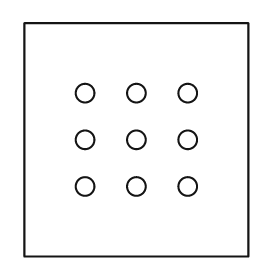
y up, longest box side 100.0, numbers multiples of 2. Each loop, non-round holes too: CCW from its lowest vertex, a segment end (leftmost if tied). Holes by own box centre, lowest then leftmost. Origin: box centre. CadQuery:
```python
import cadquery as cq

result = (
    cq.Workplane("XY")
    .moveTo(-48.0, -50.0)
    .lineTo(48.0, -50.0)
    .lineTo(48.0, 50.0)
    .lineTo(-48.0, 50.0)
    .close()
    .moveTo(-22.0, -20.0)
    .circle(4.0)
    .moveTo(0.0, -20.0)
    .circle(4.0)
    .moveTo(22.0, -20.0)
    .circle(4.0)
    .moveTo(-22.0, 0.0)
    .circle(4.0)
    .moveTo(0.0, 0.0)
    .circle(4.0)
    .moveTo(22.0, 0.0)
    .circle(4.0)
    .moveTo(-22.0, 20.0)
    .circle(4.0)
    .moveTo(0.0, 20.0)
    .circle(4.0)
    .moveTo(22.0, 20.0)
    .circle(4.0)
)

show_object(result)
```